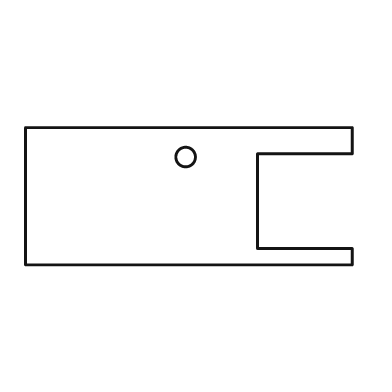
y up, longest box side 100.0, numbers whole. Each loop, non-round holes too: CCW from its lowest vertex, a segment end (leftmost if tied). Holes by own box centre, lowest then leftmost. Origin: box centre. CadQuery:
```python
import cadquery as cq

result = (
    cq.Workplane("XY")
    .moveTo(-50.0, -21.0)
    .lineTo(50.0, -21.0)
    .lineTo(50.0, -16.0)
    .lineTo(21.0, -16.0)
    .lineTo(21.0, 13.0)
    .lineTo(50.0, 13.0)
    .lineTo(50.0, 21.0)
    .lineTo(-50.0, 21.0)
    .close()
    .moveTo(-1.0, 12.0)
    .circle(3.0)
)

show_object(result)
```